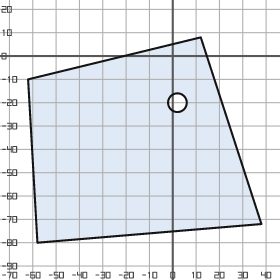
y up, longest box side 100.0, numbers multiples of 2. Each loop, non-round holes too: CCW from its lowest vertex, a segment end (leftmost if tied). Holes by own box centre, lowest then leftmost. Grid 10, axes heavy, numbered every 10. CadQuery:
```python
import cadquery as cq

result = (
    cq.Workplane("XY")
    .moveTo(-58.0, -80.0)
    .lineTo(38.0, -72.0)
    .lineTo(12.0, 8.0)
    .lineTo(-62.0, -10.0)
    .close()
    .moveTo(2.0, -20.0)
    .circle(4.0)
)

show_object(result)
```